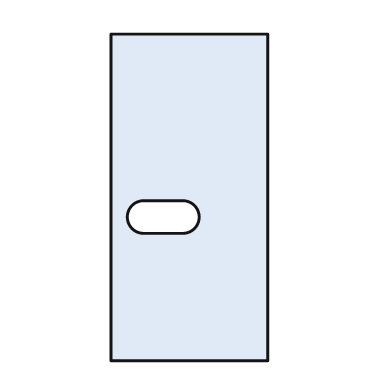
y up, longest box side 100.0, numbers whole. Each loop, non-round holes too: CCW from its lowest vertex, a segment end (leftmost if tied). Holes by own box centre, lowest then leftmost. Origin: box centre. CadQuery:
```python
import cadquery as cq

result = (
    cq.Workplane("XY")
    .moveTo(-24.0, -50.0)
    .lineTo(24.0, -50.0)
    .lineTo(24.0, 50.0)
    .lineTo(-24.0, 50.0)
    .close()
    .moveTo(-14.0, -11.0)
    .lineTo(-2.0, -11.0)
    .threePointArc((3.0, -6.0), (-2.0, -1.0))
    .lineTo(-14.0, -1.0)
    .threePointArc((-19.0, -6.0), (-14.0, -11.0))
    .close()
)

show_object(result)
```